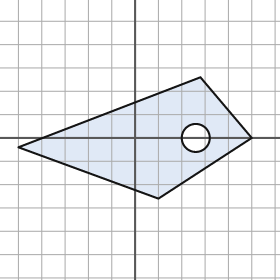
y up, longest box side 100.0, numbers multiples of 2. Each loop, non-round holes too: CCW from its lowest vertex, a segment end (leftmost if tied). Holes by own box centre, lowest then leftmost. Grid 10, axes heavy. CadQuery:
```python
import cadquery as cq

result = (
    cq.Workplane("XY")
    .moveTo(10.0, -26.0)
    .lineTo(50.0, 0.0)
    .lineTo(28.0, 26.0)
    .lineTo(-50.0, -4.0)
    .close()
    .moveTo(26.0, 0.0)
    .circle(6.0)
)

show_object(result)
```